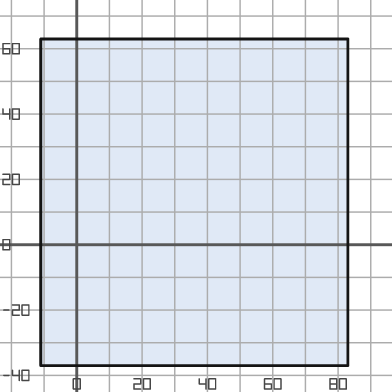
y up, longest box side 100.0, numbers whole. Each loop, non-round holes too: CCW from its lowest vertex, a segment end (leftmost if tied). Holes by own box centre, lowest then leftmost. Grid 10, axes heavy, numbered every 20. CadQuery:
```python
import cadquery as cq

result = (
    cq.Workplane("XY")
    .moveTo(-11.0, -37.0)
    .lineTo(83.0, -37.0)
    .lineTo(83.0, 63.0)
    .lineTo(-11.0, 63.0)
    .close()
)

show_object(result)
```